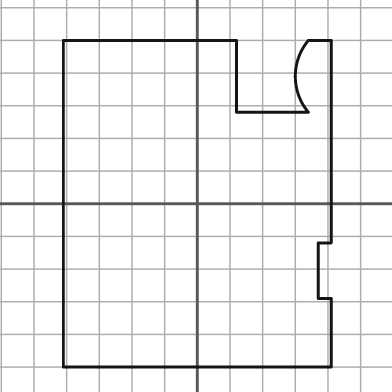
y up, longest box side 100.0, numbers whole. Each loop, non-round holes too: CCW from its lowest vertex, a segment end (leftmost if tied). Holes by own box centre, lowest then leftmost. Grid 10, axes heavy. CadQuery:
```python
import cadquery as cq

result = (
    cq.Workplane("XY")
    .moveTo(-41.0, -50.0)
    .lineTo(41.0, -50.0)
    .lineTo(41.0, -29.0)
    .lineTo(37.0, -29.0)
    .lineTo(37.0, -12.0)
    .lineTo(41.0, -12.0)
    .lineTo(41.0, 50.0)
    .lineTo(34.0, 50.0)
    .threePointArc((30.0, 39.0), (34.0, 28.0))
    .lineTo(12.0, 28.0)
    .lineTo(12.0, 50.0)
    .lineTo(-41.0, 50.0)
    .close()
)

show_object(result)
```